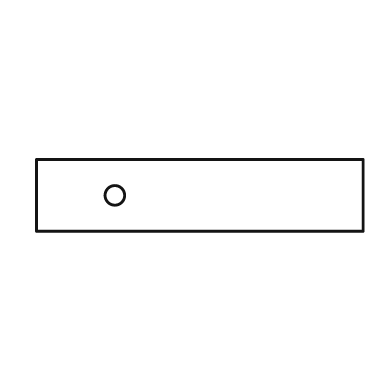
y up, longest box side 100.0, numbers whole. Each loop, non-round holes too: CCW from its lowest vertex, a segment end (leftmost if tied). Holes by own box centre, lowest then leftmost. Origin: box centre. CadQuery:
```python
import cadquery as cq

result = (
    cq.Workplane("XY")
    .moveTo(-50.0, -11.0)
    .lineTo(50.0, -11.0)
    .lineTo(50.0, 11.0)
    .lineTo(-50.0, 11.0)
    .close()
    .moveTo(-26.0, 0.0)
    .circle(3.0)
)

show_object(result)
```